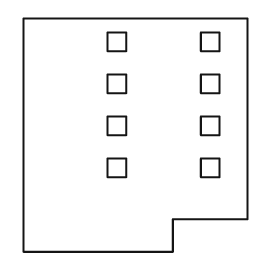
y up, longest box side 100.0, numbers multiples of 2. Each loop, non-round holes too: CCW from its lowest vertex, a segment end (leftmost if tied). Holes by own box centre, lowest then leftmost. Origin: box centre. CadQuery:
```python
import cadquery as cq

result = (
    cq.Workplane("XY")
    .moveTo(-48.0, -50.0)
    .lineTo(16.0, -50.0)
    .lineTo(16.0, -36.0)
    .lineTo(48.0, -36.0)
    .lineTo(48.0, 50.0)
    .lineTo(-48.0, 50.0)
    .close()
    .moveTo(-12.0, -18.0)
    .lineTo(-4.0, -18.0)
    .lineTo(-4.0, -10.0)
    .lineTo(-12.0, -10.0)
    .close()
    .moveTo(28.0, -18.0)
    .lineTo(36.0, -18.0)
    .lineTo(36.0, -10.0)
    .lineTo(28.0, -10.0)
    .close()
    .moveTo(-12.0, 0.0)
    .lineTo(-4.0, 0.0)
    .lineTo(-4.0, 8.0)
    .lineTo(-12.0, 8.0)
    .close()
    .moveTo(28.0, 0.0)
    .lineTo(36.0, 0.0)
    .lineTo(36.0, 8.0)
    .lineTo(28.0, 8.0)
    .close()
    .moveTo(-12.0, 18.0)
    .lineTo(-4.0, 18.0)
    .lineTo(-4.0, 26.0)
    .lineTo(-12.0, 26.0)
    .close()
    .moveTo(28.0, 18.0)
    .lineTo(36.0, 18.0)
    .lineTo(36.0, 26.0)
    .lineTo(28.0, 26.0)
    .close()
    .moveTo(-12.0, 36.0)
    .lineTo(-4.0, 36.0)
    .lineTo(-4.0, 44.0)
    .lineTo(-12.0, 44.0)
    .close()
    .moveTo(28.0, 36.0)
    .lineTo(36.0, 36.0)
    .lineTo(36.0, 44.0)
    .lineTo(28.0, 44.0)
    .close()
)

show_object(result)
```